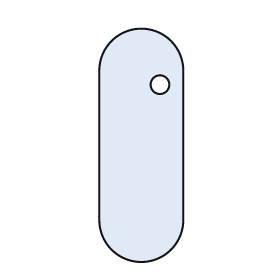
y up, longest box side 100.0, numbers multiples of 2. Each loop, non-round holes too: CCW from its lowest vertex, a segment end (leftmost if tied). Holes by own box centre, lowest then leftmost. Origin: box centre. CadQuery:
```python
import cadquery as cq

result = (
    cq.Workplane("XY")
    .moveTo(-18.0, -32.0)
    .threePointArc((0.0, -50.0), (18.0, -32.0))
    .lineTo(18.0, 32.0)
    .threePointArc((0.0, 50.0), (-18.0, 32.0))
    .close()
    .moveTo(8.0, 26.0)
    .circle(4.0)
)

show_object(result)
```